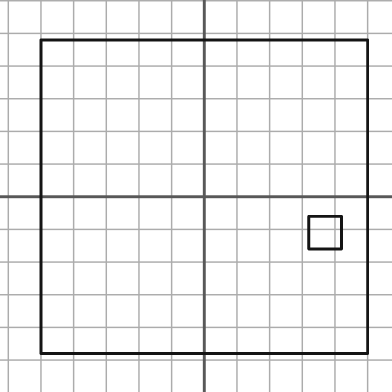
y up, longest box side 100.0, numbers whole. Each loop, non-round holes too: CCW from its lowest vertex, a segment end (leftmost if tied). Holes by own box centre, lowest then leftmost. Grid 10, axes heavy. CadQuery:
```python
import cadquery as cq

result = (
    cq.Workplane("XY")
    .moveTo(-50.0, -48.0)
    .lineTo(50.0, -48.0)
    .lineTo(50.0, 48.0)
    .lineTo(-50.0, 48.0)
    .close()
    .moveTo(32.0, -16.0)
    .lineTo(42.0, -16.0)
    .lineTo(42.0, -6.0)
    .lineTo(32.0, -6.0)
    .close()
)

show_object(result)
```